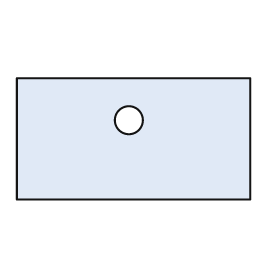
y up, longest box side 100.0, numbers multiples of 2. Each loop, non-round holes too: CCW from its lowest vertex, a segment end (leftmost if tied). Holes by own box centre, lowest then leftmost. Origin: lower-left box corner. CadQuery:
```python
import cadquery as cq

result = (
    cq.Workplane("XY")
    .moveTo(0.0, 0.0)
    .lineTo(100.0, 0.0)
    .lineTo(100.0, 52.0)
    .lineTo(0.0, 52.0)
    .close()
    .moveTo(48.0, 34.0)
    .circle(6.0)
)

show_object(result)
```